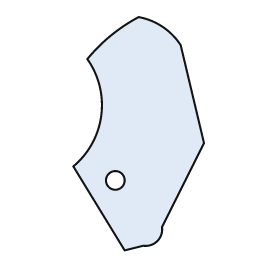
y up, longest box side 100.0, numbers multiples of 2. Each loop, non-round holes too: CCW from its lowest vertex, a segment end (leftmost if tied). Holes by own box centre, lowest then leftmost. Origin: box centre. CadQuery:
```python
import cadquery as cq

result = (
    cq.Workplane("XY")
    .moveTo(-6.0, -50.0)
    .lineTo(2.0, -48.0)
    .threePointArc((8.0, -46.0), (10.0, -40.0))
    .lineTo(28.0, -4.0)
    .lineTo(18.0, 38.0)
    .threePointArc((10.0, 46.0), (0.0, 50.0))
    .threePointArc((-12.0, 42.0), (-22.0, 32.0))
    .threePointArc((-16.0, 8.0), (-28.0, -14.0))
    .close()
    .moveTo(-10.0, -20.0)
    .circle(4.0)
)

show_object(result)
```